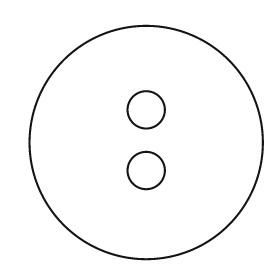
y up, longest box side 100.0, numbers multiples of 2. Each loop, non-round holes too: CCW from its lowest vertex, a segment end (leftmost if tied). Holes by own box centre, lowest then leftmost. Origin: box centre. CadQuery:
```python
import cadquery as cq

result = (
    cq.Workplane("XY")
    .moveTo(0.0, 0.0)
    .circle(50.0)
    .moveTo(0.0, -12.0)
    .circle(8.0)
    .moveTo(0.0, 14.0)
    .circle(8.0)
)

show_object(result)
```